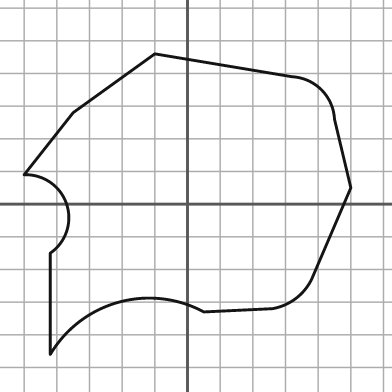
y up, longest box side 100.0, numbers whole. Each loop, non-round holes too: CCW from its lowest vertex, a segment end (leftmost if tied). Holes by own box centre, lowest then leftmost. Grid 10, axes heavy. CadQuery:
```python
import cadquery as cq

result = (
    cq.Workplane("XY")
    .moveTo(-42.0, -46.0)
    .threePointArc((-21.0, -30.0), (5.0, -33.0))
    .lineTo(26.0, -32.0)
    .threePointArc((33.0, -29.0), (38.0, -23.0))
    .lineTo(50.0, 5.0)
    .lineTo(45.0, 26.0)
    .threePointArc((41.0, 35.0), (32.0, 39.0))
    .lineTo(-10.0, 46.0)
    .lineTo(-35.0, 28.0)
    .lineTo(-50.0, 9.0)
    .threePointArc((-37.0, 0.0), (-42.0, -15.0))
    .close()
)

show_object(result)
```